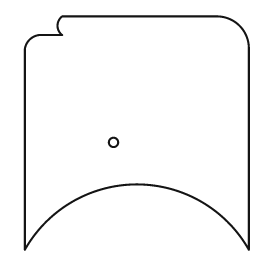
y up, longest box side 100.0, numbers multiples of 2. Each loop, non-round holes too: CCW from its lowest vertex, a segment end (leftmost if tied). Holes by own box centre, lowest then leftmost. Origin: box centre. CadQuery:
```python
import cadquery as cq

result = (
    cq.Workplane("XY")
    .moveTo(-48.0, -50.0)
    .threePointArc((0.0, -22.0), (48.0, -50.0))
    .lineTo(48.0, 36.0)
    .threePointArc((44.0, 46.0), (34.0, 50.0))
    .lineTo(-32.0, 50.0)
    .threePointArc((-34.0, 46.0), (-32.0, 42.0))
    .lineTo(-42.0, 42.0)
    .threePointArc((-46.0, 40.0), (-48.0, 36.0))
    .close()
    .moveTo(-10.0, -4.0)
    .circle(2.0)
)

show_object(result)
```